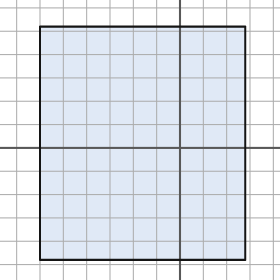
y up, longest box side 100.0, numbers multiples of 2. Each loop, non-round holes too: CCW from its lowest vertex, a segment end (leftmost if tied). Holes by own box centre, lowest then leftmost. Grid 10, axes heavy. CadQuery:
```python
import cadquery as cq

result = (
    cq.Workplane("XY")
    .moveTo(-60.0, -48.0)
    .lineTo(28.0, -48.0)
    .lineTo(28.0, 52.0)
    .lineTo(-60.0, 52.0)
    .close()
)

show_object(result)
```